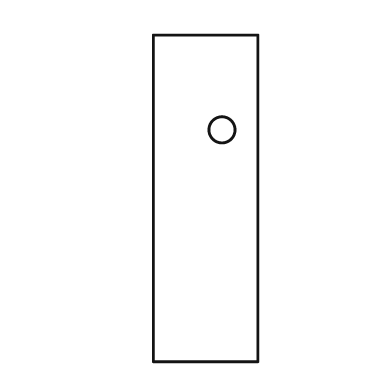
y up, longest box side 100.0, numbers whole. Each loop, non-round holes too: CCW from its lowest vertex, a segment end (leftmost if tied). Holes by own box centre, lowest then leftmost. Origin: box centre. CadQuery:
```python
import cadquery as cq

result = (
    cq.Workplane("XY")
    .moveTo(-16.0, -50.0)
    .lineTo(16.0, -50.0)
    .lineTo(16.0, 50.0)
    .lineTo(-16.0, 50.0)
    .close()
    .moveTo(5.0, 21.0)
    .circle(4.0)
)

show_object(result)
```